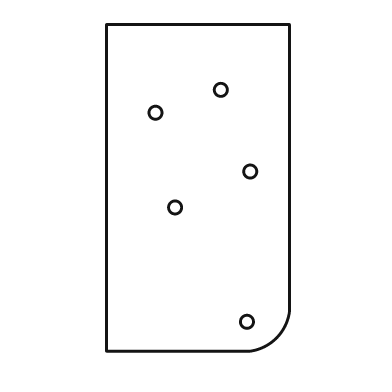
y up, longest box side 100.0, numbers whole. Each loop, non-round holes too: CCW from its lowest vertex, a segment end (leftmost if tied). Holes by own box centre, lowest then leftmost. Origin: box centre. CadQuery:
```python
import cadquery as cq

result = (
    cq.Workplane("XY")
    .moveTo(-28.0, -50.0)
    .lineTo(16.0, -50.0)
    .threePointArc((24.0, -46.0), (28.0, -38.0))
    .lineTo(28.0, 50.0)
    .lineTo(-28.0, 50.0)
    .close()
    .moveTo(15.0, -41.0)
    .circle(2.0)
    .moveTo(-7.0, -6.0)
    .circle(2.0)
    .moveTo(16.0, 5.0)
    .circle(2.0)
    .moveTo(-13.0, 23.0)
    .circle(2.0)
    .moveTo(7.0, 30.0)
    .circle(2.0)
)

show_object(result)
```